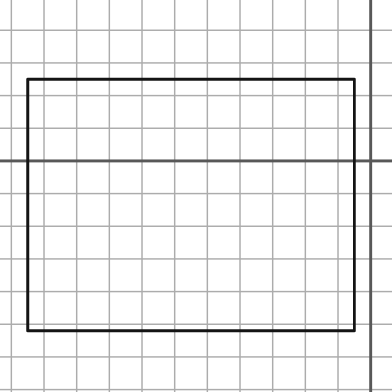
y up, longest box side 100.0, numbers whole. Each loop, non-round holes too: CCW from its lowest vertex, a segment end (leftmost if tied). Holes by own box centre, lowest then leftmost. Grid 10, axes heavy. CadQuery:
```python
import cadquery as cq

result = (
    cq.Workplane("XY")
    .moveTo(-105.0, -52.0)
    .lineTo(-5.0, -52.0)
    .lineTo(-5.0, 25.0)
    .lineTo(-105.0, 25.0)
    .close()
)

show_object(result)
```